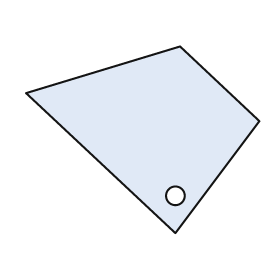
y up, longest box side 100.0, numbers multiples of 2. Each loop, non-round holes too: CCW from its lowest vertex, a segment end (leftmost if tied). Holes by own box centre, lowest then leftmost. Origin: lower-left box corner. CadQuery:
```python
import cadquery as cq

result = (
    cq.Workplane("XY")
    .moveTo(64.0, 0.0)
    .lineTo(100.0, 48.0)
    .lineTo(66.0, 80.0)
    .lineTo(0.0, 60.0)
    .close()
    .moveTo(64.0, 16.0)
    .circle(4.0)
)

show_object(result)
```